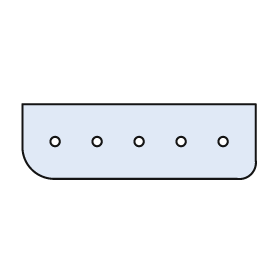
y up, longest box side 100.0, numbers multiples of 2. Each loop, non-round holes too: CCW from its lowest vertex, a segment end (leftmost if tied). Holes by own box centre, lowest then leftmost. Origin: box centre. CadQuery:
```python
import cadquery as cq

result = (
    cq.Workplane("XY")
    .moveTo(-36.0, -16.0)
    .lineTo(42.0, -16.0)
    .threePointArc((48.0, -14.0), (50.0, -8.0))
    .lineTo(50.0, 16.0)
    .lineTo(-50.0, 16.0)
    .lineTo(-50.0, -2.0)
    .threePointArc((-46.0, -12.0), (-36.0, -16.0))
    .close()
    .moveTo(-36.0, 0.0)
    .circle(2.0)
    .moveTo(-18.0, 0.0)
    .circle(2.0)
    .moveTo(0.0, 0.0)
    .circle(2.0)
    .moveTo(18.0, 0.0)
    .circle(2.0)
    .moveTo(36.0, 0.0)
    .circle(2.0)
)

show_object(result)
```